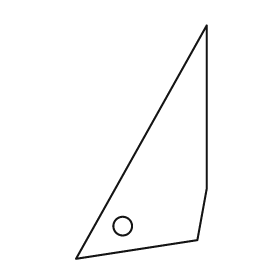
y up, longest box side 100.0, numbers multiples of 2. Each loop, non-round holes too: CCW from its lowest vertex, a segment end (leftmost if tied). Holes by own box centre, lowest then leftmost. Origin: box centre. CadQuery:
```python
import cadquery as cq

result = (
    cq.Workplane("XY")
    .moveTo(-28.0, -50.0)
    .lineTo(24.0, -42.0)
    .lineTo(28.0, -20.0)
    .lineTo(28.0, 50.0)
    .close()
    .moveTo(-8.0, -36.0)
    .circle(4.0)
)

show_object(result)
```